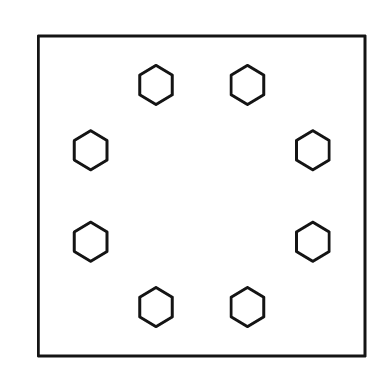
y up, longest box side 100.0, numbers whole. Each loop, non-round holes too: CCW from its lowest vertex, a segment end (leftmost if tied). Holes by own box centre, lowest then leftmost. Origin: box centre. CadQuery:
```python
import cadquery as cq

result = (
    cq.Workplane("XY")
    .moveTo(-50.0, -49.0)
    .lineTo(50.0, -49.0)
    .lineTo(50.0, 49.0)
    .lineTo(-50.0, 49.0)
    .close()
    .moveTo(-14.0, -40.0)
    .lineTo(-9.0, -37.0)
    .lineTo(-9.0, -31.0)
    .lineTo(-14.0, -28.0)
    .lineTo(-19.0, -31.0)
    .lineTo(-19.0, -37.0)
    .close()
    .moveTo(14.0, -40.0)
    .lineTo(19.0, -37.0)
    .lineTo(19.0, -31.0)
    .lineTo(14.0, -28.0)
    .lineTo(9.0, -31.0)
    .lineTo(9.0, -37.0)
    .close()
    .moveTo(-34.0, -20.0)
    .lineTo(-29.0, -17.0)
    .lineTo(-29.0, -11.0)
    .lineTo(-34.0, -8.0)
    .lineTo(-39.0, -11.0)
    .lineTo(-39.0, -17.0)
    .close()
    .moveTo(34.0, -20.0)
    .lineTo(39.0, -17.0)
    .lineTo(39.0, -11.0)
    .lineTo(34.0, -8.0)
    .lineTo(29.0, -11.0)
    .lineTo(29.0, -17.0)
    .close()
    .moveTo(-34.0, 8.0)
    .lineTo(-29.0, 11.0)
    .lineTo(-29.0, 17.0)
    .lineTo(-34.0, 20.0)
    .lineTo(-39.0, 17.0)
    .lineTo(-39.0, 11.0)
    .close()
    .moveTo(34.0, 8.0)
    .lineTo(39.0, 11.0)
    .lineTo(39.0, 17.0)
    .lineTo(34.0, 20.0)
    .lineTo(29.0, 17.0)
    .lineTo(29.0, 11.0)
    .close()
    .moveTo(-14.0, 28.0)
    .lineTo(-9.0, 31.0)
    .lineTo(-9.0, 37.0)
    .lineTo(-14.0, 40.0)
    .lineTo(-19.0, 37.0)
    .lineTo(-19.0, 31.0)
    .close()
    .moveTo(14.0, 28.0)
    .lineTo(19.0, 31.0)
    .lineTo(19.0, 37.0)
    .lineTo(14.0, 40.0)
    .lineTo(9.0, 37.0)
    .lineTo(9.0, 31.0)
    .close()
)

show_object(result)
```